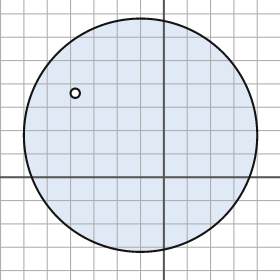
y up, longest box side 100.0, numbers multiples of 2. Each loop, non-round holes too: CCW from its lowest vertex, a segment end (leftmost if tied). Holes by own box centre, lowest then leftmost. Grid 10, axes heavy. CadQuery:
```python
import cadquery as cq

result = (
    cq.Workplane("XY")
    .moveTo(-10.0, 18.0)
    .circle(50.0)
    .moveTo(-38.0, 36.0)
    .circle(2.0)
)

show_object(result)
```